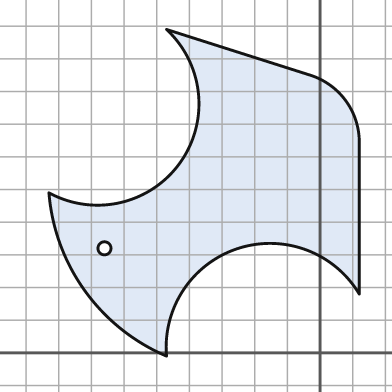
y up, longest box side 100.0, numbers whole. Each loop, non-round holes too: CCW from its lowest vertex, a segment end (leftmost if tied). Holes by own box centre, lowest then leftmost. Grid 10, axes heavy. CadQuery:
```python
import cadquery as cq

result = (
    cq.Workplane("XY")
    .moveTo(-47.0, -1.0)
    .threePointArc((-25.0, 32.0), (12.0, 18.0))
    .lineTo(12.0, 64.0)
    .threePointArc((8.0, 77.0), (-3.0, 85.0))
    .lineTo(-47.0, 99.0)
    .threePointArc((-43.0, 58.0), (-83.0, 49.0))
    .threePointArc((-72.0, 19.0), (-47.0, -1.0))
    .close()
    .moveTo(-66.0, 32.0)
    .circle(2.0)
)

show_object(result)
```